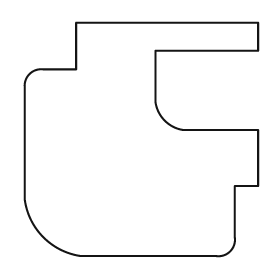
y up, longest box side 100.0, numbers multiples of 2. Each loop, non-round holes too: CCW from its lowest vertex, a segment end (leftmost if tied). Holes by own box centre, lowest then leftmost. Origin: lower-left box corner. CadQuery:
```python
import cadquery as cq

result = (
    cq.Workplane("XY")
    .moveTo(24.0, 0.0)
    .lineTo(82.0, 0.0)
    .threePointArc((88.0, 2.0), (90.0, 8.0))
    .lineTo(90.0, 30.0)
    .lineTo(100.0, 30.0)
    .lineTo(100.0, 54.0)
    .lineTo(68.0, 54.0)
    .threePointArc((60.0, 58.0), (56.0, 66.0))
    .lineTo(56.0, 88.0)
    .lineTo(100.0, 88.0)
    .lineTo(100.0, 100.0)
    .lineTo(22.0, 100.0)
    .lineTo(22.0, 80.0)
    .lineTo(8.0, 80.0)
    .threePointArc((2.0, 78.0), (0.0, 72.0))
    .lineTo(0.0, 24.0)
    .threePointArc((8.0, 8.0), (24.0, 0.0))
    .close()
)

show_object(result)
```